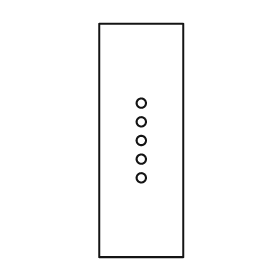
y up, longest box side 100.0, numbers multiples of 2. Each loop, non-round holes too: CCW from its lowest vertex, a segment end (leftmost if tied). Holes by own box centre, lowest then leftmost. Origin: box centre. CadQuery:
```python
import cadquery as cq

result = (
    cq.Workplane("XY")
    .moveTo(-18.0, -50.0)
    .lineTo(18.0, -50.0)
    .lineTo(18.0, 50.0)
    .lineTo(-18.0, 50.0)
    .close()
    .moveTo(0.0, -16.0)
    .circle(2.0)
    .moveTo(0.0, -8.0)
    .circle(2.0)
    .moveTo(0.0, 0.0)
    .circle(2.0)
    .moveTo(0.0, 8.0)
    .circle(2.0)
    .moveTo(0.0, 16.0)
    .circle(2.0)
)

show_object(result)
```